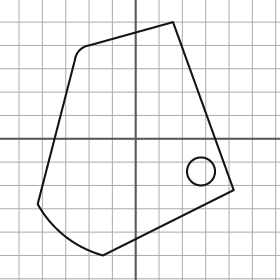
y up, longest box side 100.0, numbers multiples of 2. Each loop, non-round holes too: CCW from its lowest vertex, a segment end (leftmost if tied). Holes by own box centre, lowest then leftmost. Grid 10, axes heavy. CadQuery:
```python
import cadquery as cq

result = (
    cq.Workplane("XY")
    .moveTo(-14.0, -50.0)
    .lineTo(42.0, -22.0)
    .lineTo(16.0, 50.0)
    .lineTo(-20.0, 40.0)
    .threePointArc((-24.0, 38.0), (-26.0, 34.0))
    .lineTo(-42.0, -28.0)
    .threePointArc((-30.0, -42.0), (-14.0, -50.0))
    .close()
    .moveTo(28.0, -14.0)
    .circle(6.0)
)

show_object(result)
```